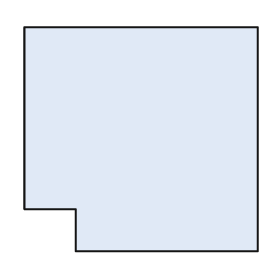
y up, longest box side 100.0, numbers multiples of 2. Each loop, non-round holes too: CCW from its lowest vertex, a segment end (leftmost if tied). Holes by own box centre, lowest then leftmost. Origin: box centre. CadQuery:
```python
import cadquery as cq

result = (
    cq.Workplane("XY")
    .moveTo(-28.0, -48.0)
    .lineTo(50.0, -48.0)
    .lineTo(50.0, 48.0)
    .lineTo(-50.0, 48.0)
    .lineTo(-50.0, -30.0)
    .lineTo(-28.0, -30.0)
    .close()
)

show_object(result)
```